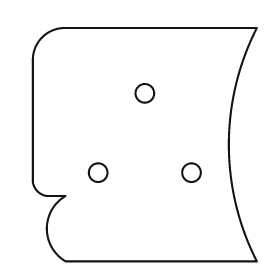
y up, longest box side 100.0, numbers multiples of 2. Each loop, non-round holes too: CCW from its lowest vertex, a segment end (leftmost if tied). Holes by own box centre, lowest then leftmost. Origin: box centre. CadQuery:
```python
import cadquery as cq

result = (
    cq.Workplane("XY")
    .moveTo(-34.0, -50.0)
    .lineTo(48.0, -50.0)
    .threePointArc((36.0, 0.0), (48.0, 50.0))
    .lineTo(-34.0, 50.0)
    .threePointArc((-44.0, 46.0), (-48.0, 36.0))
    .lineTo(-48.0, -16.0)
    .threePointArc((-46.0, -20.0), (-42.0, -22.0))
    .lineTo(-34.0, -22.0)
    .threePointArc((-42.0, -36.0), (-34.0, -50.0))
    .close()
    .moveTo(-20.0, -12.0)
    .circle(4.0)
    .moveTo(20.0, -12.0)
    .circle(4.0)
    .moveTo(0.0, 22.0)
    .circle(4.0)
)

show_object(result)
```